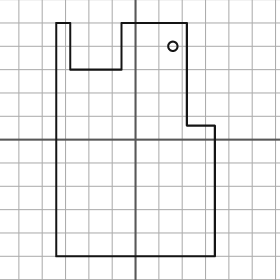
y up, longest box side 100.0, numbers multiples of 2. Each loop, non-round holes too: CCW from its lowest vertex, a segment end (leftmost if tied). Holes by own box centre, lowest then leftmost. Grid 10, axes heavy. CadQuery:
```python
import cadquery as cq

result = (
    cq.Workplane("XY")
    .moveTo(-34.0, -50.0)
    .lineTo(34.0, -50.0)
    .lineTo(34.0, 6.0)
    .lineTo(22.0, 6.0)
    .lineTo(22.0, 50.0)
    .lineTo(-6.0, 50.0)
    .lineTo(-6.0, 30.0)
    .lineTo(-28.0, 30.0)
    .lineTo(-28.0, 50.0)
    .lineTo(-34.0, 50.0)
    .close()
    .moveTo(16.0, 40.0)
    .circle(2.0)
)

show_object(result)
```